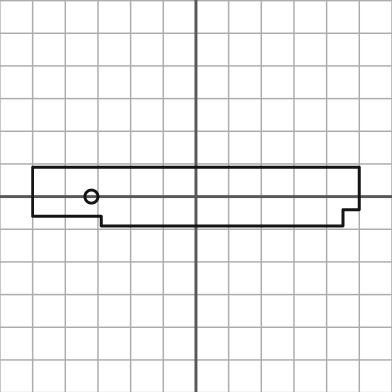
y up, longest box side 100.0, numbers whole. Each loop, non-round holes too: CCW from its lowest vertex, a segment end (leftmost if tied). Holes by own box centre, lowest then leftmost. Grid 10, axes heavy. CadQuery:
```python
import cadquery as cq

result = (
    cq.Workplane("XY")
    .moveTo(-29.0, -9.0)
    .lineTo(45.0, -9.0)
    .lineTo(45.0, -4.0)
    .lineTo(50.0, -4.0)
    .lineTo(50.0, 9.0)
    .lineTo(-50.0, 9.0)
    .lineTo(-50.0, -6.0)
    .lineTo(-29.0, -6.0)
    .close()
    .moveTo(-32.0, 0.0)
    .circle(2.0)
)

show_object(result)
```